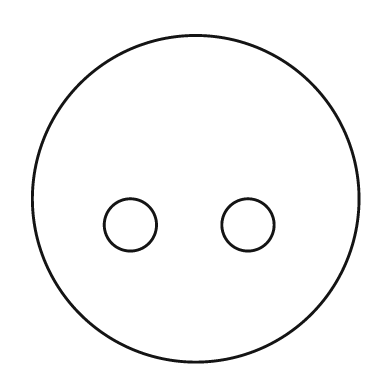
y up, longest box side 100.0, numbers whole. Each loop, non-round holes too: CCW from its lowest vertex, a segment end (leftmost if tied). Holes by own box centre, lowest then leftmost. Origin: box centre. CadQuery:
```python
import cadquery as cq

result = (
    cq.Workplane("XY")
    .moveTo(0.0, 0.0)
    .circle(50.0)
    .moveTo(-20.0, -8.0)
    .circle(8.0)
    .moveTo(16.0, -8.0)
    .circle(8.0)
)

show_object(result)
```